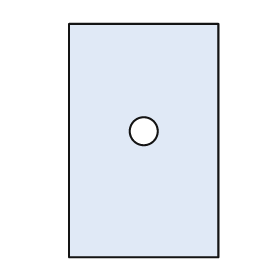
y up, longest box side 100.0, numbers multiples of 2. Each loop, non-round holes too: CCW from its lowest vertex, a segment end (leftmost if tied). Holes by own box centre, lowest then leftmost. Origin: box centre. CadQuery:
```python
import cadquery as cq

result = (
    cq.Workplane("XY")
    .moveTo(-32.0, -50.0)
    .lineTo(32.0, -50.0)
    .lineTo(32.0, 50.0)
    .lineTo(-32.0, 50.0)
    .close()
    .moveTo(0.0, 4.0)
    .circle(6.0)
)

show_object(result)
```